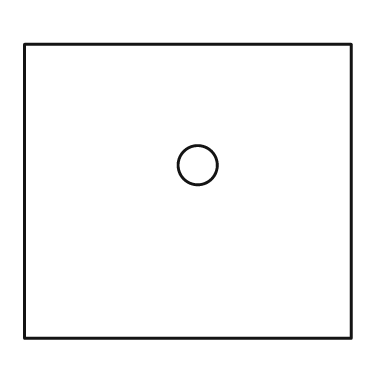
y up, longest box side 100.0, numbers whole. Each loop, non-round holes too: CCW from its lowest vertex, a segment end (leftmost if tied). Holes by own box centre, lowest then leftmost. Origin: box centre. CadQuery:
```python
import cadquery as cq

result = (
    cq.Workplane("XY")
    .moveTo(-50.0, -45.0)
    .lineTo(50.0, -45.0)
    .lineTo(50.0, 45.0)
    .lineTo(-50.0, 45.0)
    .close()
    .moveTo(3.0, 8.0)
    .circle(6.0)
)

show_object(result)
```